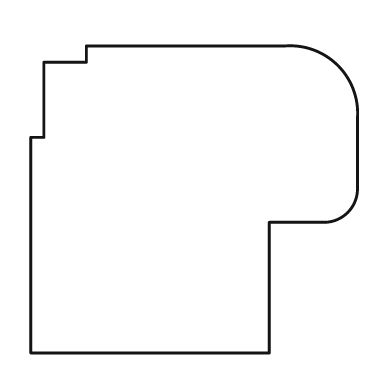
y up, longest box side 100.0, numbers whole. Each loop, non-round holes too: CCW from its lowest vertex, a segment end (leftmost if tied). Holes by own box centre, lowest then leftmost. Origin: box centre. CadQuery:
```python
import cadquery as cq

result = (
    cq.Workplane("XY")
    .moveTo(-50.0, -47.0)
    .lineTo(23.0, -47.0)
    .lineTo(23.0, -7.0)
    .lineTo(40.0, -7.0)
    .threePointArc((47.0, -4.0), (50.0, 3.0))
    .lineTo(50.0, 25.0)
    .threePointArc((44.0, 41.0), (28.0, 47.0))
    .lineTo(-33.0, 47.0)
    .lineTo(-33.0, 42.0)
    .lineTo(-46.0, 42.0)
    .lineTo(-46.0, 19.0)
    .lineTo(-50.0, 19.0)
    .close()
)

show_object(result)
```